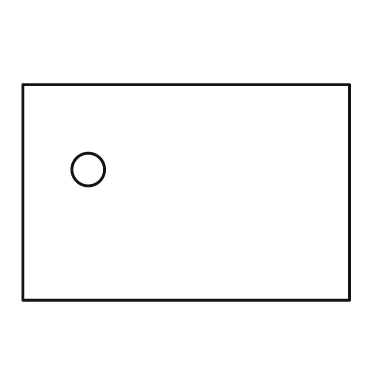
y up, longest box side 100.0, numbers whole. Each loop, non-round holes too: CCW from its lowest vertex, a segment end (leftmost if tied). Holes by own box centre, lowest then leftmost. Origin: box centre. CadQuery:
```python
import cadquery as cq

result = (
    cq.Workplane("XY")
    .moveTo(-50.0, -33.0)
    .lineTo(50.0, -33.0)
    .lineTo(50.0, 33.0)
    .lineTo(-50.0, 33.0)
    .close()
    .moveTo(-30.0, 7.0)
    .circle(5.0)
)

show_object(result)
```